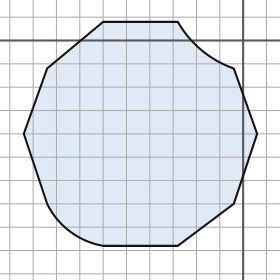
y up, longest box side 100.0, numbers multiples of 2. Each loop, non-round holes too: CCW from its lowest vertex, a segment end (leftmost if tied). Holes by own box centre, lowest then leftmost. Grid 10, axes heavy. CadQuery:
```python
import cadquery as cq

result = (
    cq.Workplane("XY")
    .moveTo(-60.0, -88.0)
    .lineTo(-28.0, -88.0)
    .lineTo(-4.0, -70.0)
    .lineTo(6.0, -40.0)
    .lineTo(-4.0, -12.0)
    .threePointArc((-18.0, -4.0), (-28.0, 8.0))
    .lineTo(-60.0, 8.0)
    .lineTo(-84.0, -12.0)
    .lineTo(-94.0, -40.0)
    .lineTo(-84.0, -70.0)
    .threePointArc((-74.0, -82.0), (-60.0, -88.0))
    .close()
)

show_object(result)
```